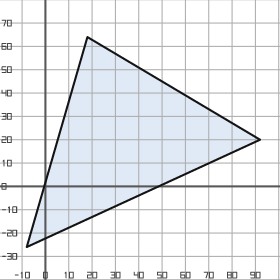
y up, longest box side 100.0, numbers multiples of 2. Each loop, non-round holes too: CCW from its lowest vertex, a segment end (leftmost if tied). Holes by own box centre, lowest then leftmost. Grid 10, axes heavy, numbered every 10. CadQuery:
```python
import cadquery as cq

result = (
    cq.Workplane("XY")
    .moveTo(-8.0, -26.0)
    .lineTo(92.0, 20.0)
    .lineTo(18.0, 64.0)
    .close()
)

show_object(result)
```